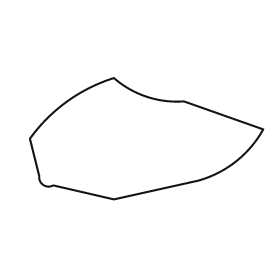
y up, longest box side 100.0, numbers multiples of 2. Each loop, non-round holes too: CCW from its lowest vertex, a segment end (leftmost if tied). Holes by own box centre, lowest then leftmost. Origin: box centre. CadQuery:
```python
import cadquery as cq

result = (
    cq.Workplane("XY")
    .moveTo(-14.0, -26.0)
    .lineTo(22.0, -18.0)
    .threePointArc((38.0, -10.0), (50.0, 4.0))
    .lineTo(16.0, 16.0)
    .threePointArc((0.0, 18.0), (-14.0, 26.0))
    .threePointArc((-34.0, 16.0), (-50.0, 0.0))
    .lineTo(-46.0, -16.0)
    .threePointArc((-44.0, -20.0), (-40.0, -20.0))
    .close()
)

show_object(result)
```